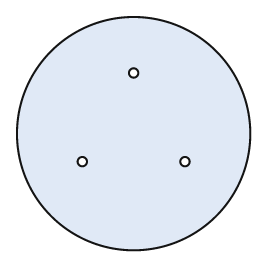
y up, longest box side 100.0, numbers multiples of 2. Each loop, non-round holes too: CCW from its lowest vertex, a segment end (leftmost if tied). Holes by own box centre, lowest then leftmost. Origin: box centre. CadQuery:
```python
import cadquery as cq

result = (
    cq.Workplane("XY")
    .moveTo(0.0, 0.0)
    .circle(50.0)
    .moveTo(-22.0, -12.0)
    .circle(2.0)
    .moveTo(22.0, -12.0)
    .circle(2.0)
    .moveTo(0.0, 26.0)
    .circle(2.0)
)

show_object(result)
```